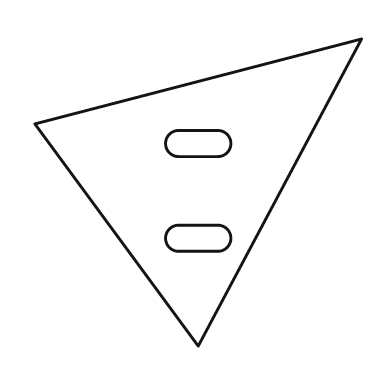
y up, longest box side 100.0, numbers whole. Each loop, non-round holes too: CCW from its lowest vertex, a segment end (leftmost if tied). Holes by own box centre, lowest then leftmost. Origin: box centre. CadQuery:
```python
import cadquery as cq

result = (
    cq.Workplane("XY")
    .moveTo(0.0, -47.0)
    .lineTo(50.0, 47.0)
    .lineTo(-50.0, 21.0)
    .close()
    .moveTo(-6.0, -18.0)
    .lineTo(6.0, -18.0)
    .threePointArc((10.0, -14.0), (6.0, -10.0))
    .lineTo(-6.0, -10.0)
    .threePointArc((-10.0, -14.0), (-6.0, -18.0))
    .close()
    .moveTo(-6.0, 11.0)
    .lineTo(6.0, 11.0)
    .threePointArc((10.0, 15.0), (6.0, 19.0))
    .lineTo(-6.0, 19.0)
    .threePointArc((-10.0, 15.0), (-6.0, 11.0))
    .close()
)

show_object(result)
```